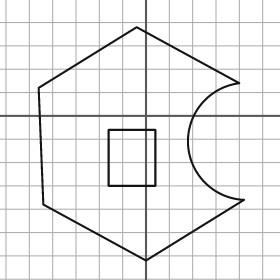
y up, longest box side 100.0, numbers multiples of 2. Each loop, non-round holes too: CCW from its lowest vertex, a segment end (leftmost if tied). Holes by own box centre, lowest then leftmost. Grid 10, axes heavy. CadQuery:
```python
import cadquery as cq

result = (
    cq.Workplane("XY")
    .moveTo(0.0, -62.0)
    .lineTo(42.0, -36.0)
    .threePointArc((18.0, -12.0), (40.0, 14.0))
    .lineTo(-4.0, 38.0)
    .lineTo(-46.0, 12.0)
    .lineTo(-44.0, -38.0)
    .close()
    .moveTo(-16.0, -30.0)
    .lineTo(4.0, -30.0)
    .lineTo(4.0, -6.0)
    .lineTo(-16.0, -6.0)
    .close()
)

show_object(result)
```